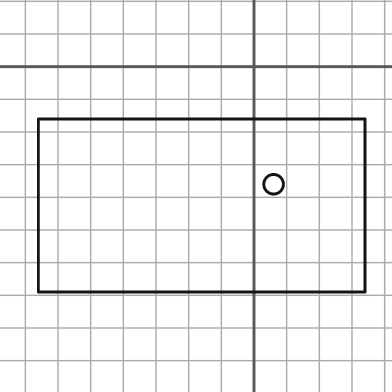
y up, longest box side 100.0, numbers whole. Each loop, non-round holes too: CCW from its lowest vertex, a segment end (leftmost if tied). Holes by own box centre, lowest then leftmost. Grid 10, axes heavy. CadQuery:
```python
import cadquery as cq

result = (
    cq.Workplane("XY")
    .moveTo(-66.0, -69.0)
    .lineTo(34.0, -69.0)
    .lineTo(34.0, -16.0)
    .lineTo(-66.0, -16.0)
    .close()
    .moveTo(6.0, -36.0)
    .circle(3.0)
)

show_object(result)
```